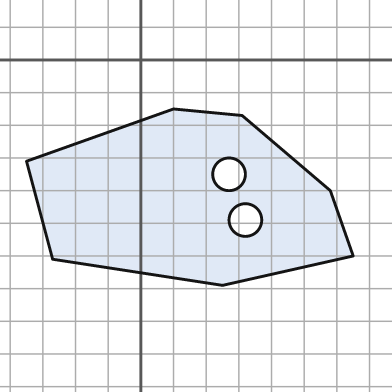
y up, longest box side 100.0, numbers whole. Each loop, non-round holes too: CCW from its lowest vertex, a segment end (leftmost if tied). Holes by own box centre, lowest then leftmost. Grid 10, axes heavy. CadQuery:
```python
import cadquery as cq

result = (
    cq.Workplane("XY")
    .moveTo(25.0, -69.0)
    .lineTo(65.0, -60.0)
    .lineTo(58.0, -40.0)
    .lineTo(31.0, -17.0)
    .lineTo(10.0, -15.0)
    .lineTo(-35.0, -31.0)
    .lineTo(-27.0, -61.0)
    .close()
    .moveTo(32.0, -49.0)
    .circle(5.0)
    .moveTo(27.0, -35.0)
    .circle(5.0)
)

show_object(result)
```